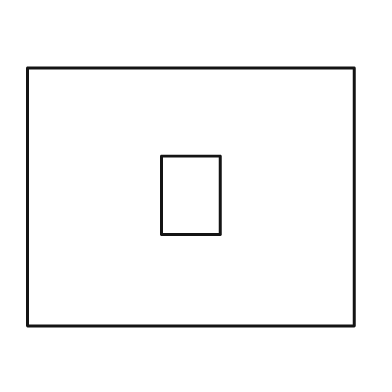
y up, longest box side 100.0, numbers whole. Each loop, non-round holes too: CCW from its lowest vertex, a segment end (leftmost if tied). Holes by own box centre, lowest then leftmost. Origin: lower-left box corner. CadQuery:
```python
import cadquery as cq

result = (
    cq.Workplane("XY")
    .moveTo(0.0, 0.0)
    .lineTo(100.0, 0.0)
    .lineTo(100.0, 79.0)
    .lineTo(0.0, 79.0)
    .close()
    .moveTo(41.0, 28.0)
    .lineTo(59.0, 28.0)
    .lineTo(59.0, 52.0)
    .lineTo(41.0, 52.0)
    .close()
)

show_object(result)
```